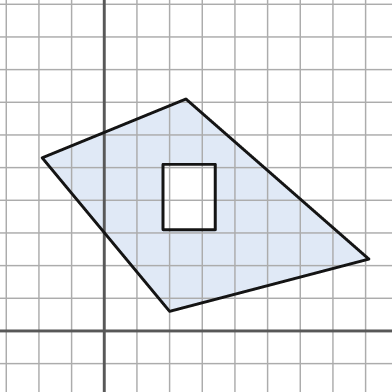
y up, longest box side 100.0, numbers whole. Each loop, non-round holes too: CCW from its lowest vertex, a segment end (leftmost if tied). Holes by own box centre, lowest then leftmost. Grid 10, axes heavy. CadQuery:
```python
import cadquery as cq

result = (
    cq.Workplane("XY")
    .moveTo(20.0, 6.0)
    .lineTo(81.0, 22.0)
    .lineTo(25.0, 71.0)
    .lineTo(-19.0, 53.0)
    .close()
    .moveTo(18.0, 31.0)
    .lineTo(34.0, 31.0)
    .lineTo(34.0, 51.0)
    .lineTo(18.0, 51.0)
    .close()
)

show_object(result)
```